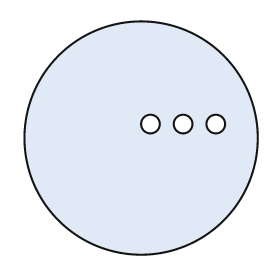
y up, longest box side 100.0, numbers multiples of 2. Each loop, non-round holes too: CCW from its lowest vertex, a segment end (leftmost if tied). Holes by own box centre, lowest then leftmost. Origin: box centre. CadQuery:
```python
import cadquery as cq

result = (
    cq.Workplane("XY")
    .moveTo(0.0, 0.0)
    .circle(50.0)
    .moveTo(4.0, 6.0)
    .circle(4.0)
    .moveTo(18.0, 6.0)
    .circle(4.0)
    .moveTo(32.0, 6.0)
    .circle(4.0)
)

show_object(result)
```